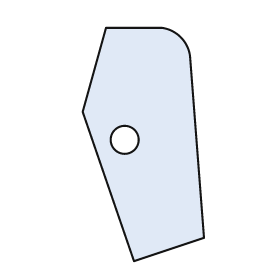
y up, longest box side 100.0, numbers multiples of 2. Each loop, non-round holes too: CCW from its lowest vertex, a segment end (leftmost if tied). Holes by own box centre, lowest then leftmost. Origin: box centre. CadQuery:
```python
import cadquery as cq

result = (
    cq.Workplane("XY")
    .moveTo(-4.0, -50.0)
    .lineTo(26.0, -40.0)
    .lineTo(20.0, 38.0)
    .threePointArc((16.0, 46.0), (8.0, 50.0))
    .lineTo(-16.0, 50.0)
    .lineTo(-26.0, 14.0)
    .close()
    .moveTo(-8.0, 2.0)
    .circle(6.0)
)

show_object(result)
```